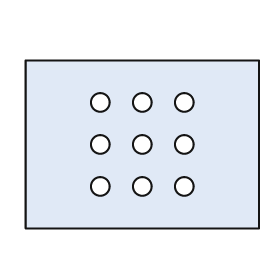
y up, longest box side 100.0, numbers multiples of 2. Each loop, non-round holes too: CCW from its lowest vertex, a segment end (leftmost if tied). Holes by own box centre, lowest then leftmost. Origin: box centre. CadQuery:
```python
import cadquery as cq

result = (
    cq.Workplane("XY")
    .moveTo(-50.0, -36.0)
    .lineTo(50.0, -36.0)
    .lineTo(50.0, 36.0)
    .lineTo(-50.0, 36.0)
    .close()
    .moveTo(-18.0, -18.0)
    .circle(4.0)
    .moveTo(0.0, -18.0)
    .circle(4.0)
    .moveTo(18.0, -18.0)
    .circle(4.0)
    .moveTo(-18.0, 0.0)
    .circle(4.0)
    .moveTo(0.0, 0.0)
    .circle(4.0)
    .moveTo(18.0, 0.0)
    .circle(4.0)
    .moveTo(-18.0, 18.0)
    .circle(4.0)
    .moveTo(0.0, 18.0)
    .circle(4.0)
    .moveTo(18.0, 18.0)
    .circle(4.0)
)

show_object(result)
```